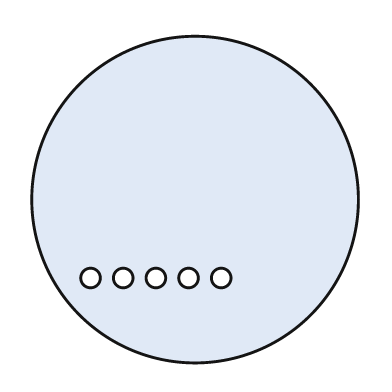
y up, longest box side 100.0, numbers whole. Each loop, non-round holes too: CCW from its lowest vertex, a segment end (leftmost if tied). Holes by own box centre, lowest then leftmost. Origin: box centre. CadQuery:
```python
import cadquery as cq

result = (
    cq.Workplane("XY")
    .moveTo(0.0, 0.0)
    .circle(50.0)
    .moveTo(-32.0, -24.0)
    .circle(3.0)
    .moveTo(-22.0, -24.0)
    .circle(3.0)
    .moveTo(-12.0, -24.0)
    .circle(3.0)
    .moveTo(-2.0, -24.0)
    .circle(3.0)
    .moveTo(8.0, -24.0)
    .circle(3.0)
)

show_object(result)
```